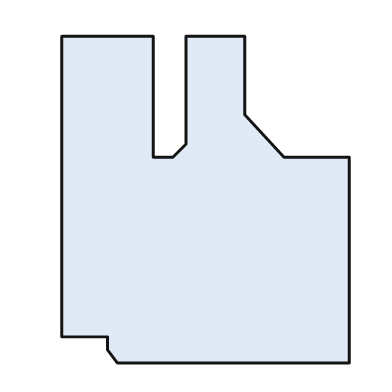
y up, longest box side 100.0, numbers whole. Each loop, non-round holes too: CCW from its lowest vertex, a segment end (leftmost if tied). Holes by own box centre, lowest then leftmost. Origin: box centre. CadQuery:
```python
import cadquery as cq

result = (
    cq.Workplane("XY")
    .moveTo(-27.0, -50.0)
    .lineTo(44.0, -50.0)
    .lineTo(44.0, 13.0)
    .lineTo(24.0, 13.0)
    .lineTo(12.0, 26.0)
    .lineTo(12.0, 50.0)
    .lineTo(-6.0, 50.0)
    .lineTo(-6.0, 17.0)
    .lineTo(-10.0, 13.0)
    .lineTo(-16.0, 13.0)
    .lineTo(-16.0, 50.0)
    .lineTo(-44.0, 50.0)
    .lineTo(-44.0, -42.0)
    .lineTo(-30.0, -42.0)
    .lineTo(-30.0, -46.0)
    .close()
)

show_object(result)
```